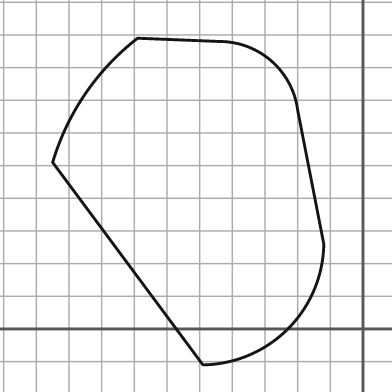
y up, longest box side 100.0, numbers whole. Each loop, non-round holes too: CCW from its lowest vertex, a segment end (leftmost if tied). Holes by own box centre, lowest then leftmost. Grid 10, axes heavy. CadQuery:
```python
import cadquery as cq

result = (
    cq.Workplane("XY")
    .moveTo(-49.0, -11.0)
    .threePointArc((-23.0, 0.0), (-12.0, 26.0))
    .lineTo(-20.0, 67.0)
    .threePointArc((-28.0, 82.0), (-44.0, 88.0))
    .lineTo(-69.0, 89.0)
    .threePointArc((-85.0, 72.0), (-95.0, 51.0))
    .close()
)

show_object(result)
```